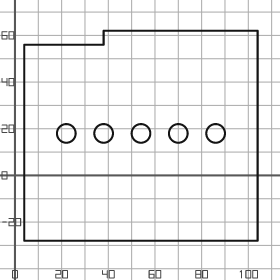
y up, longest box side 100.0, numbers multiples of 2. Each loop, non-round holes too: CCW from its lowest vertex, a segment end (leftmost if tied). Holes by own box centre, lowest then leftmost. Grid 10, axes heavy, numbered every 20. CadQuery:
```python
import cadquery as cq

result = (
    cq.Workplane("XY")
    .moveTo(4.0, -28.0)
    .lineTo(104.0, -28.0)
    .lineTo(104.0, 62.0)
    .lineTo(38.0, 62.0)
    .lineTo(38.0, 56.0)
    .lineTo(4.0, 56.0)
    .close()
    .moveTo(22.0, 18.0)
    .circle(4.0)
    .moveTo(38.0, 18.0)
    .circle(4.0)
    .moveTo(54.0, 18.0)
    .circle(4.0)
    .moveTo(70.0, 18.0)
    .circle(4.0)
    .moveTo(86.0, 18.0)
    .circle(4.0)
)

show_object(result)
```